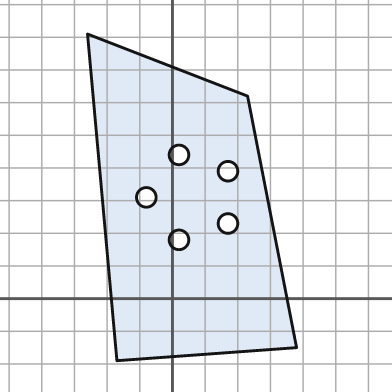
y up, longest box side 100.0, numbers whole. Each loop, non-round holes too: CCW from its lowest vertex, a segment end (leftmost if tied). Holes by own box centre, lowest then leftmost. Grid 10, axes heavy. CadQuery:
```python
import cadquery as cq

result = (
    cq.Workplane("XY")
    .moveTo(-17.0, -19.0)
    .lineTo(38.0, -15.0)
    .lineTo(23.0, 62.0)
    .lineTo(-26.0, 81.0)
    .close()
    .moveTo(2.0, 18.0)
    .circle(3.0)
    .moveTo(17.0, 23.0)
    .circle(3.0)
    .moveTo(-8.0, 31.0)
    .circle(3.0)
    .moveTo(17.0, 39.0)
    .circle(3.0)
    .moveTo(2.0, 44.0)
    .circle(3.0)
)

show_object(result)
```